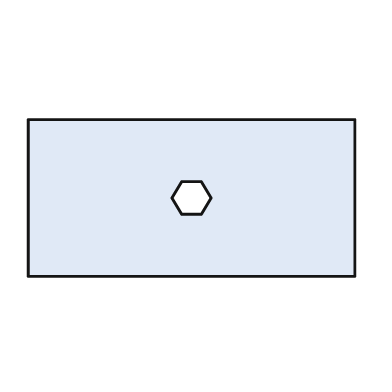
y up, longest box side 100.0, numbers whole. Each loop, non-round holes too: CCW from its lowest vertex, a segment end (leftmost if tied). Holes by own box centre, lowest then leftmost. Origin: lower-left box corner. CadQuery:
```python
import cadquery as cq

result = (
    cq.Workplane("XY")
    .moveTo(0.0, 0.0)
    .lineTo(100.0, 0.0)
    .lineTo(100.0, 48.0)
    .lineTo(0.0, 48.0)
    .close()
    .moveTo(47.0, 19.0)
    .lineTo(53.0, 19.0)
    .lineTo(56.0, 24.0)
    .lineTo(53.0, 29.0)
    .lineTo(47.0, 29.0)
    .lineTo(44.0, 24.0)
    .close()
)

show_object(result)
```